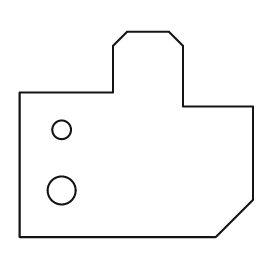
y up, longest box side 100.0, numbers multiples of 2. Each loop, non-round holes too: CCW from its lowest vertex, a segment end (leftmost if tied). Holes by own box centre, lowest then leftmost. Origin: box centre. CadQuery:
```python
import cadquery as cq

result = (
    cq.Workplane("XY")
    .moveTo(-50.0, -44.0)
    .lineTo(34.0, -44.0)
    .lineTo(50.0, -28.0)
    .lineTo(50.0, 12.0)
    .lineTo(20.0, 12.0)
    .lineTo(20.0, 38.0)
    .lineTo(14.0, 44.0)
    .lineTo(-4.0, 44.0)
    .lineTo(-10.0, 38.0)
    .lineTo(-10.0, 18.0)
    .lineTo(-50.0, 18.0)
    .close()
    .moveTo(-32.0, -24.0)
    .circle(6.0)
    .moveTo(-32.0, 2.0)
    .circle(4.0)
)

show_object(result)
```